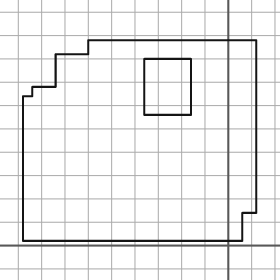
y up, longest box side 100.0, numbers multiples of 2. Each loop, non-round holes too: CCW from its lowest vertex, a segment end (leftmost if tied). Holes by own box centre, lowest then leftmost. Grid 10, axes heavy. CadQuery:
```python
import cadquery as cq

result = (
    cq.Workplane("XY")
    .moveTo(-88.0, 2.0)
    .lineTo(6.0, 2.0)
    .lineTo(6.0, 14.0)
    .lineTo(12.0, 14.0)
    .lineTo(12.0, 88.0)
    .lineTo(-60.0, 88.0)
    .lineTo(-60.0, 82.0)
    .lineTo(-74.0, 82.0)
    .lineTo(-74.0, 68.0)
    .lineTo(-84.0, 68.0)
    .lineTo(-84.0, 64.0)
    .lineTo(-88.0, 64.0)
    .close()
    .moveTo(-36.0, 56.0)
    .lineTo(-16.0, 56.0)
    .lineTo(-16.0, 80.0)
    .lineTo(-36.0, 80.0)
    .close()
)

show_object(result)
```